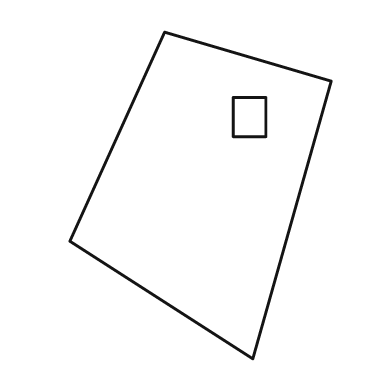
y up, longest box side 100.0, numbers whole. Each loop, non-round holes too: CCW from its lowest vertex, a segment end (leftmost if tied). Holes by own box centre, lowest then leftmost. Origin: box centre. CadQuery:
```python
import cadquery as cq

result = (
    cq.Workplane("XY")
    .moveTo(16.0, -50.0)
    .lineTo(40.0, 35.0)
    .lineTo(-11.0, 50.0)
    .lineTo(-40.0, -14.0)
    .close()
    .moveTo(10.0, 18.0)
    .lineTo(20.0, 18.0)
    .lineTo(20.0, 30.0)
    .lineTo(10.0, 30.0)
    .close()
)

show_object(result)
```